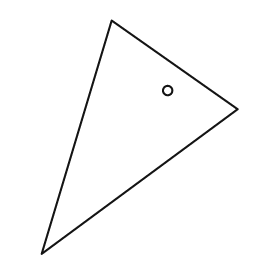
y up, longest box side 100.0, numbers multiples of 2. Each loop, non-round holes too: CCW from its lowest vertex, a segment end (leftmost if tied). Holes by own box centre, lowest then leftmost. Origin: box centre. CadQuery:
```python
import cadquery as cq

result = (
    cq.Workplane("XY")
    .moveTo(-42.0, -50.0)
    .lineTo(42.0, 12.0)
    .lineTo(-12.0, 50.0)
    .close()
    .moveTo(12.0, 20.0)
    .circle(2.0)
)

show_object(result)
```